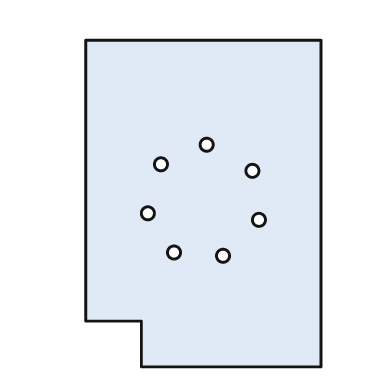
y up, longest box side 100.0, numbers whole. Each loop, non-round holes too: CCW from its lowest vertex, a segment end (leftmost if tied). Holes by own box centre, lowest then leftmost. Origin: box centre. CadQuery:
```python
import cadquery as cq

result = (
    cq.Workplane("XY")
    .moveTo(-19.0, -50.0)
    .lineTo(36.0, -50.0)
    .lineTo(36.0, 50.0)
    .lineTo(-36.0, 50.0)
    .lineTo(-36.0, -36.0)
    .lineTo(-19.0, -36.0)
    .close()
    .moveTo(6.0, -16.0)
    .circle(2.0)
    .moveTo(-9.0, -15.0)
    .circle(2.0)
    .moveTo(17.0, -5.0)
    .circle(2.0)
    .moveTo(-17.0, -3.0)
    .circle(2.0)
    .moveTo(15.0, 10.0)
    .circle(2.0)
    .moveTo(-13.0, 12.0)
    .circle(2.0)
    .moveTo(1.0, 18.0)
    .circle(2.0)
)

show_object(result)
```